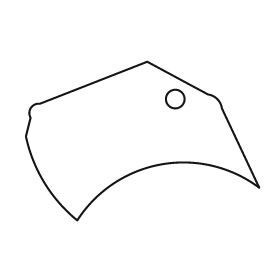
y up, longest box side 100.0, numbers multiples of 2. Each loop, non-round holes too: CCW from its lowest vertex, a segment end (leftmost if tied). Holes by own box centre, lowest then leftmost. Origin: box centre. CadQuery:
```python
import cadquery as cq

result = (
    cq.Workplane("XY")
    .moveTo(-28.0, -34.0)
    .threePointArc((8.0, -10.0), (50.0, -20.0))
    .lineTo(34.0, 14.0)
    .threePointArc((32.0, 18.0), (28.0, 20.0))
    .lineTo(2.0, 34.0)
    .lineTo(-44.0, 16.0)
    .threePointArc((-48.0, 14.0), (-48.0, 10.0))
    .lineTo(-50.0, 2.0)
    .threePointArc((-42.0, -18.0), (-28.0, -34.0))
    .close()
    .moveTo(14.0, 18.0)
    .circle(4.0)
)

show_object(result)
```